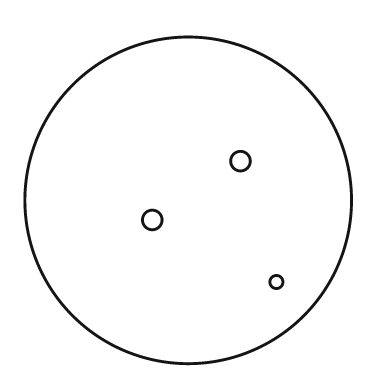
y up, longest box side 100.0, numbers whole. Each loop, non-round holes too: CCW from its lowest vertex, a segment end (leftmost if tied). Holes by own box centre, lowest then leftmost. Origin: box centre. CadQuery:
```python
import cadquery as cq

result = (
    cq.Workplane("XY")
    .moveTo(0.0, 0.0)
    .circle(50.0)
    .moveTo(27.0, -25.0)
    .circle(2.0)
    .moveTo(-11.0, -6.0)
    .circle(3.0)
    .moveTo(16.0, 12.0)
    .circle(3.0)
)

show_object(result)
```